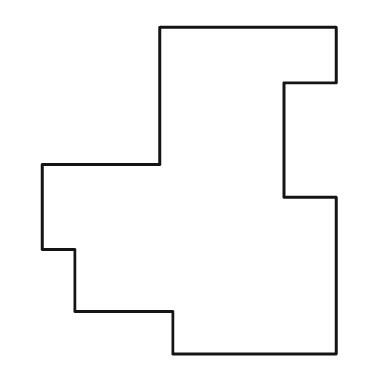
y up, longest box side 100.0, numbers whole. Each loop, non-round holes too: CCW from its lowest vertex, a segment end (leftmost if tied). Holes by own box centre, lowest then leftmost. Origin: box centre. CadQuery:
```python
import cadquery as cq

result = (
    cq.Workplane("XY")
    .moveTo(-5.0, -50.0)
    .lineTo(45.0, -50.0)
    .lineTo(45.0, -2.0)
    .lineTo(29.0, -2.0)
    .lineTo(29.0, 33.0)
    .lineTo(45.0, 33.0)
    .lineTo(45.0, 50.0)
    .lineTo(-9.0, 50.0)
    .lineTo(-9.0, 8.0)
    .lineTo(-45.0, 8.0)
    .lineTo(-45.0, -18.0)
    .lineTo(-35.0, -18.0)
    .lineTo(-35.0, -37.0)
    .lineTo(-5.0, -37.0)
    .close()
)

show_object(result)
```